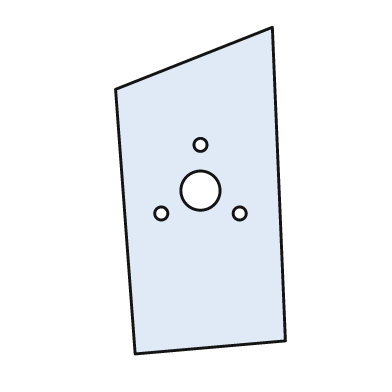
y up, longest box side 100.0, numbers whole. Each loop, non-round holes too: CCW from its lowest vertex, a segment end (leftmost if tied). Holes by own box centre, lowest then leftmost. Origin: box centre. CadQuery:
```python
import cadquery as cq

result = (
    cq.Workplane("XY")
    .moveTo(-20.0, -50.0)
    .lineTo(26.0, -46.0)
    .lineTo(22.0, 50.0)
    .lineTo(-26.0, 31.0)
    .close()
    .moveTo(-12.0, -7.0)
    .circle(2.0)
    .moveTo(12.0, -7.0)
    .circle(2.0)
    .moveTo(0.0, 0.0)
    .circle(6.0)
    .moveTo(0.0, 14.0)
    .circle(2.0)
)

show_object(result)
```